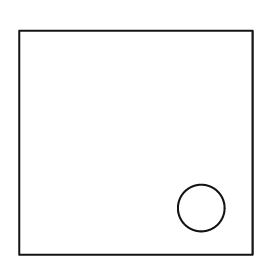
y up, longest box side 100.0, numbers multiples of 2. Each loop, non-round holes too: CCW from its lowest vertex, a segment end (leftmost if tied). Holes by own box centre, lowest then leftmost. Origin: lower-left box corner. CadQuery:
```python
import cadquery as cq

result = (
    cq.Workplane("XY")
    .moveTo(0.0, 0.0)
    .lineTo(100.0, 0.0)
    .lineTo(100.0, 96.0)
    .lineTo(0.0, 96.0)
    .close()
    .moveTo(78.0, 20.0)
    .circle(10.0)
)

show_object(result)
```